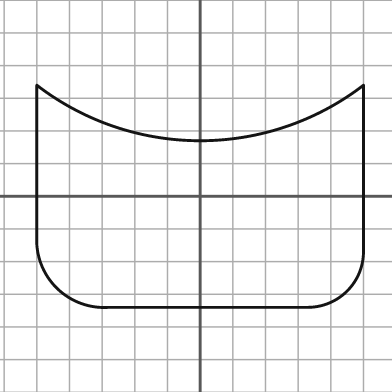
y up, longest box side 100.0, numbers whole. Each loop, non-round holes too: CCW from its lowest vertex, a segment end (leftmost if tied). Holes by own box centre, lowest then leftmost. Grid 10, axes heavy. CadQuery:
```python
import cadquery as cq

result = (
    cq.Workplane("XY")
    .moveTo(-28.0, -34.0)
    .lineTo(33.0, -34.0)
    .threePointArc((45.0, -29.0), (50.0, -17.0))
    .lineTo(50.0, 34.0)
    .threePointArc((0.0, 17.0), (-50.0, 34.0))
    .lineTo(-50.0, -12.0)
    .threePointArc((-44.0, -28.0), (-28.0, -34.0))
    .close()
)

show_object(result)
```